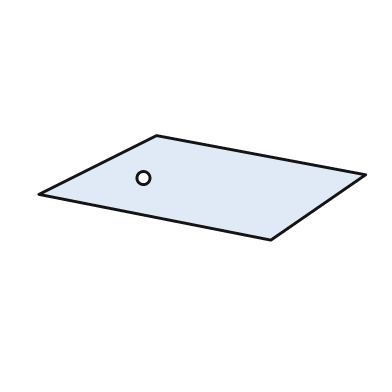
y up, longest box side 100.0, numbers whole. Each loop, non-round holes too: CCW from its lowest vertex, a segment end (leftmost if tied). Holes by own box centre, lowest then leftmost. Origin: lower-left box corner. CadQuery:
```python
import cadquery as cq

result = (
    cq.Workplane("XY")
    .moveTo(71.0, 0.0)
    .lineTo(100.0, 20.0)
    .lineTo(36.0, 32.0)
    .lineTo(0.0, 14.0)
    .close()
    .moveTo(32.0, 19.0)
    .circle(2.0)
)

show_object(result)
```